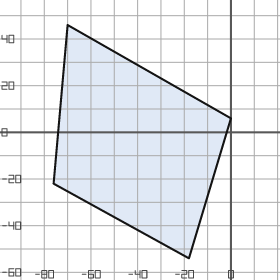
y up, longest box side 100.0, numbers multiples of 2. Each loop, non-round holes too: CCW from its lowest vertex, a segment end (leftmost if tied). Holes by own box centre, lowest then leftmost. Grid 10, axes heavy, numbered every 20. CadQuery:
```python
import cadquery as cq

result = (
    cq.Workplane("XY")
    .moveTo(-18.0, -54.0)
    .lineTo(0.0, 6.0)
    .lineTo(-70.0, 46.0)
    .lineTo(-76.0, -22.0)
    .close()
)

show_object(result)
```